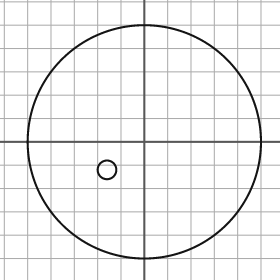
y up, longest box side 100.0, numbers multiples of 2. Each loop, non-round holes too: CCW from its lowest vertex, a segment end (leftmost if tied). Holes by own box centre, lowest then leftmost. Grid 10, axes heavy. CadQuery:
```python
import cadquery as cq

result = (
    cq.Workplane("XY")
    .moveTo(0.0, 0.0)
    .circle(50.0)
    .moveTo(-16.0, -12.0)
    .circle(4.0)
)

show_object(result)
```